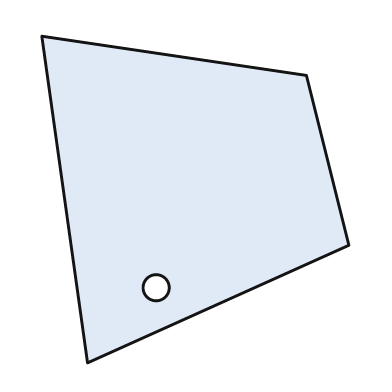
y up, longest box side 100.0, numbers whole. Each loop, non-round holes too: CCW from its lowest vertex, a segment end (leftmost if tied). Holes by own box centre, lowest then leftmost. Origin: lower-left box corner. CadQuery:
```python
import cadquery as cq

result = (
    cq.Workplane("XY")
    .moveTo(14.0, 0.0)
    .lineTo(94.0, 36.0)
    .lineTo(81.0, 88.0)
    .lineTo(0.0, 100.0)
    .close()
    .moveTo(35.0, 23.0)
    .circle(4.0)
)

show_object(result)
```